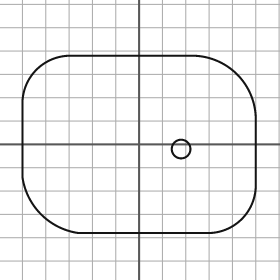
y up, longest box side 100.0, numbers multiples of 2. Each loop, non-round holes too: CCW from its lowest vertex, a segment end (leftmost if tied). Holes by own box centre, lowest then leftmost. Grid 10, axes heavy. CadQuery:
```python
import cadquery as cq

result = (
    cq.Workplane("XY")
    .moveTo(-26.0, -38.0)
    .lineTo(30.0, -38.0)
    .threePointArc((44.0, -32.0), (50.0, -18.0))
    .lineTo(50.0, 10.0)
    .threePointArc((42.0, 30.0), (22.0, 38.0))
    .lineTo(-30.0, 38.0)
    .threePointArc((-44.0, 32.0), (-50.0, 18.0))
    .lineTo(-50.0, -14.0)
    .threePointArc((-42.0, -30.0), (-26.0, -38.0))
    .close()
    .moveTo(18.0, -2.0)
    .circle(4.0)
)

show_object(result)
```